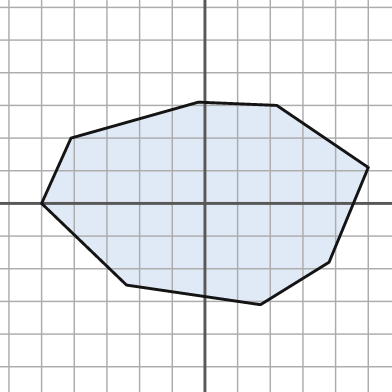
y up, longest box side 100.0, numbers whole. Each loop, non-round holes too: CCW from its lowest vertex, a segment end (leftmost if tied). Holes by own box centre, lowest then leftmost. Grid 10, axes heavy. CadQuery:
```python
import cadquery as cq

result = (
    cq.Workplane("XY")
    .moveTo(17.0, -31.0)
    .lineTo(38.0, -18.0)
    .lineTo(50.0, 11.0)
    .lineTo(22.0, 30.0)
    .lineTo(-2.0, 31.0)
    .lineTo(-41.0, 20.0)
    .lineTo(-50.0, 0.0)
    .lineTo(-24.0, -25.0)
    .close()
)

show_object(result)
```